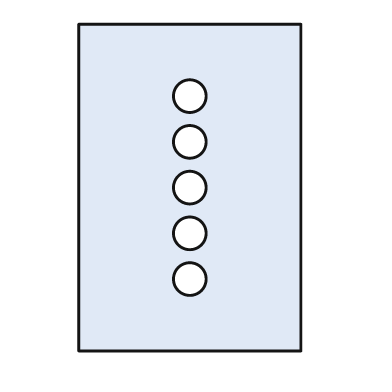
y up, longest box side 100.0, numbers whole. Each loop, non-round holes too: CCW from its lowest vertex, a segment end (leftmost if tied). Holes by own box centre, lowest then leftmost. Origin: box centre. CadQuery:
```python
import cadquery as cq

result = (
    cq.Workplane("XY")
    .moveTo(-34.0, -50.0)
    .lineTo(34.0, -50.0)
    .lineTo(34.0, 50.0)
    .lineTo(-34.0, 50.0)
    .close()
    .moveTo(0.0, -28.0)
    .circle(5.0)
    .moveTo(0.0, -14.0)
    .circle(5.0)
    .moveTo(0.0, 0.0)
    .circle(5.0)
    .moveTo(0.0, 14.0)
    .circle(5.0)
    .moveTo(0.0, 28.0)
    .circle(5.0)
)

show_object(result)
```